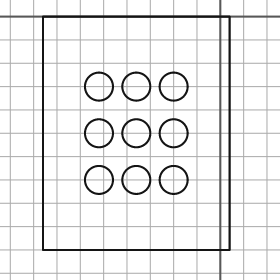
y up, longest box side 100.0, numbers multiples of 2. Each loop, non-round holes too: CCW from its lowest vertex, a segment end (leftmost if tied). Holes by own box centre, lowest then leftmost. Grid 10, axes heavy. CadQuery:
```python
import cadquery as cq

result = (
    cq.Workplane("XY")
    .moveTo(-76.0, -100.0)
    .lineTo(4.0, -100.0)
    .lineTo(4.0, 0.0)
    .lineTo(-76.0, 0.0)
    .close()
    .moveTo(-52.0, -70.0)
    .circle(6.0)
    .moveTo(-36.0, -70.0)
    .circle(6.0)
    .moveTo(-20.0, -70.0)
    .circle(6.0)
    .moveTo(-52.0, -50.0)
    .circle(6.0)
    .moveTo(-36.0, -50.0)
    .circle(6.0)
    .moveTo(-20.0, -50.0)
    .circle(6.0)
    .moveTo(-52.0, -30.0)
    .circle(6.0)
    .moveTo(-36.0, -30.0)
    .circle(6.0)
    .moveTo(-20.0, -30.0)
    .circle(6.0)
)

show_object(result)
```